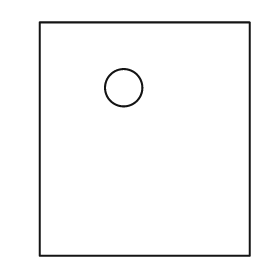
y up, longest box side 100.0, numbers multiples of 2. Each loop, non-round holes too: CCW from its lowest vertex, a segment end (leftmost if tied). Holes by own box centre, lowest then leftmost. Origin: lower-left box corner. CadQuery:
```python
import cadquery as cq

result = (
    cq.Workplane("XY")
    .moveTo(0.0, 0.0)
    .lineTo(90.0, 0.0)
    .lineTo(90.0, 100.0)
    .lineTo(0.0, 100.0)
    .close()
    .moveTo(36.0, 72.0)
    .circle(8.0)
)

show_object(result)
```